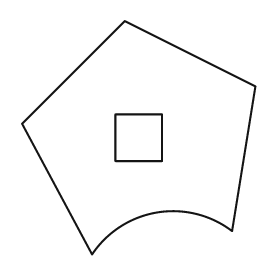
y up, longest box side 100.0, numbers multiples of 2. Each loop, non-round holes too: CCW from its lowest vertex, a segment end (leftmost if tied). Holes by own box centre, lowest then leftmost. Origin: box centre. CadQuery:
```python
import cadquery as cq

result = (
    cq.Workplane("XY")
    .moveTo(-20.0, -50.0)
    .threePointArc((8.0, -32.0), (40.0, -40.0))
    .lineTo(50.0, 22.0)
    .lineTo(-6.0, 50.0)
    .lineTo(-50.0, 6.0)
    .close()
    .moveTo(-10.0, -10.0)
    .lineTo(10.0, -10.0)
    .lineTo(10.0, 10.0)
    .lineTo(-10.0, 10.0)
    .close()
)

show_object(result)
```